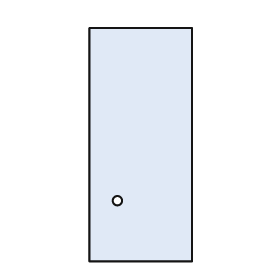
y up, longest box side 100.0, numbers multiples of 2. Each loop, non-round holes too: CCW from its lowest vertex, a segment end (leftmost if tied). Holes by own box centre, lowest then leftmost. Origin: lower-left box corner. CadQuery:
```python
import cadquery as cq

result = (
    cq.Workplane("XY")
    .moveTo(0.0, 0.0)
    .lineTo(44.0, 0.0)
    .lineTo(44.0, 100.0)
    .lineTo(0.0, 100.0)
    .close()
    .moveTo(12.0, 26.0)
    .circle(2.0)
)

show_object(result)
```